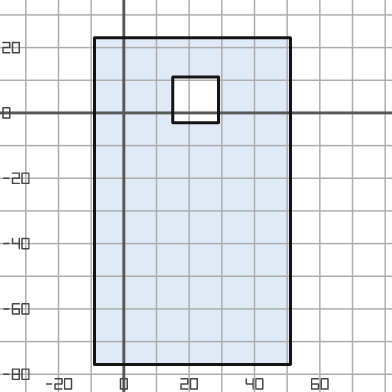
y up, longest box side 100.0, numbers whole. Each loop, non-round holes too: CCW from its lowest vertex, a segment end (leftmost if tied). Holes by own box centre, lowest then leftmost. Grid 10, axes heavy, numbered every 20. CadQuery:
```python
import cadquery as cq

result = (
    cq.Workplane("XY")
    .moveTo(-9.0, -77.0)
    .lineTo(51.0, -77.0)
    .lineTo(51.0, 23.0)
    .lineTo(-9.0, 23.0)
    .close()
    .moveTo(15.0, -3.0)
    .lineTo(29.0, -3.0)
    .lineTo(29.0, 11.0)
    .lineTo(15.0, 11.0)
    .close()
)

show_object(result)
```